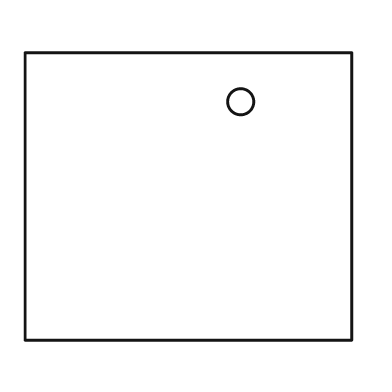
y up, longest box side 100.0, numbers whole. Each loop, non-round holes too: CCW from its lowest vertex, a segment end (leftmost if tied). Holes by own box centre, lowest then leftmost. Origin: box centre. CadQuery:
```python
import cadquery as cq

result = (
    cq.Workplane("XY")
    .moveTo(-50.0, -44.0)
    .lineTo(50.0, -44.0)
    .lineTo(50.0, 44.0)
    .lineTo(-50.0, 44.0)
    .close()
    .moveTo(16.0, 29.0)
    .circle(4.0)
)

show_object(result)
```